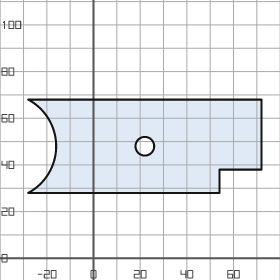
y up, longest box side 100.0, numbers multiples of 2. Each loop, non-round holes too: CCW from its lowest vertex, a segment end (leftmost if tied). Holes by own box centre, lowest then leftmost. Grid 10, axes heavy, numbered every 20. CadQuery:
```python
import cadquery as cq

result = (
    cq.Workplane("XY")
    .moveTo(-28.0, 28.0)
    .lineTo(54.0, 28.0)
    .lineTo(54.0, 38.0)
    .lineTo(72.0, 38.0)
    .lineTo(72.0, 68.0)
    .lineTo(-28.0, 68.0)
    .threePointArc((-16.0, 48.0), (-28.0, 28.0))
    .close()
    .moveTo(22.0, 48.0)
    .circle(4.0)
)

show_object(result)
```